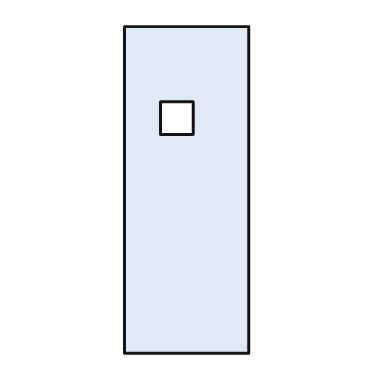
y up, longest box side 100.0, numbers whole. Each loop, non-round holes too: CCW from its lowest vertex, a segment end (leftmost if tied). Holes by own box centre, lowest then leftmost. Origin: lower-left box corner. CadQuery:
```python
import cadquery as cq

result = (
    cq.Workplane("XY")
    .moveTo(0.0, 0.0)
    .lineTo(38.0, 0.0)
    .lineTo(38.0, 100.0)
    .lineTo(0.0, 100.0)
    .close()
    .moveTo(11.0, 67.0)
    .lineTo(21.0, 67.0)
    .lineTo(21.0, 77.0)
    .lineTo(11.0, 77.0)
    .close()
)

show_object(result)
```